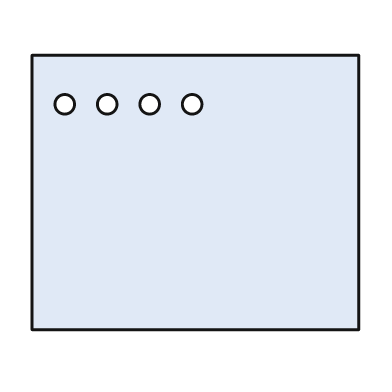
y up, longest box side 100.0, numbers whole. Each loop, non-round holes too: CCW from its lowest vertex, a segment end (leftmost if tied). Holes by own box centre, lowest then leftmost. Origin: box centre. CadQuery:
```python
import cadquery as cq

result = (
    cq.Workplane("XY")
    .moveTo(-50.0, -42.0)
    .lineTo(50.0, -42.0)
    .lineTo(50.0, 42.0)
    .lineTo(-50.0, 42.0)
    .close()
    .moveTo(-40.0, 27.0)
    .circle(3.0)
    .moveTo(-27.0, 27.0)
    .circle(3.0)
    .moveTo(-14.0, 27.0)
    .circle(3.0)
    .moveTo(-1.0, 27.0)
    .circle(3.0)
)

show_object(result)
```